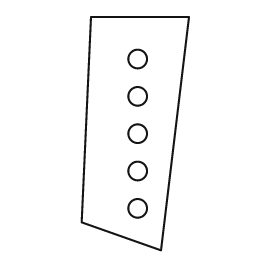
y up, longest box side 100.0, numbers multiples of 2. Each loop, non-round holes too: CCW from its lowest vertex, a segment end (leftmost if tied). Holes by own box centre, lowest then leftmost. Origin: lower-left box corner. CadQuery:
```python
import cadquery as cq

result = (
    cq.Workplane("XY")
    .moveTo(34.0, 0.0)
    .lineTo(46.0, 100.0)
    .lineTo(4.0, 100.0)
    .lineTo(0.0, 12.0)
    .close()
    .moveTo(24.0, 18.0)
    .circle(4.0)
    .moveTo(24.0, 34.0)
    .circle(4.0)
    .moveTo(24.0, 50.0)
    .circle(4.0)
    .moveTo(24.0, 66.0)
    .circle(4.0)
    .moveTo(24.0, 82.0)
    .circle(4.0)
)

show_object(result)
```